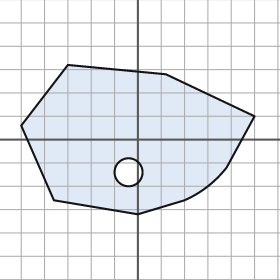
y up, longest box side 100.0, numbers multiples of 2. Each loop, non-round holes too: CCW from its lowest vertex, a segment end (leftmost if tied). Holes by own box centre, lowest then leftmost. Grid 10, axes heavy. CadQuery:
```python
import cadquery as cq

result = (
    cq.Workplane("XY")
    .moveTo(0.0, -32.0)
    .lineTo(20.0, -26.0)
    .threePointArc((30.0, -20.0), (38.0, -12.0))
    .lineTo(50.0, 10.0)
    .lineTo(12.0, 28.0)
    .lineTo(-30.0, 32.0)
    .lineTo(-50.0, 6.0)
    .lineTo(-36.0, -26.0)
    .close()
    .moveTo(-4.0, -14.0)
    .circle(6.0)
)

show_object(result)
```